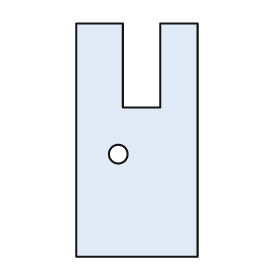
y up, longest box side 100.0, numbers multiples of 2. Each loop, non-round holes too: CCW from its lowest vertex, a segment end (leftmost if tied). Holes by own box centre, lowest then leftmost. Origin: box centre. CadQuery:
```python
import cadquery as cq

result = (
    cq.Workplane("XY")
    .moveTo(-26.0, -50.0)
    .lineTo(26.0, -50.0)
    .lineTo(26.0, 50.0)
    .lineTo(10.0, 50.0)
    .lineTo(10.0, 14.0)
    .lineTo(-6.0, 14.0)
    .lineTo(-6.0, 50.0)
    .lineTo(-26.0, 50.0)
    .close()
    .moveTo(-8.0, -6.0)
    .circle(4.0)
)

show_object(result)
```